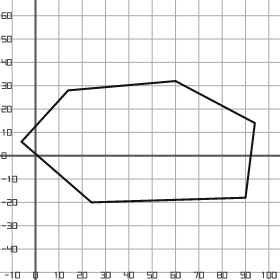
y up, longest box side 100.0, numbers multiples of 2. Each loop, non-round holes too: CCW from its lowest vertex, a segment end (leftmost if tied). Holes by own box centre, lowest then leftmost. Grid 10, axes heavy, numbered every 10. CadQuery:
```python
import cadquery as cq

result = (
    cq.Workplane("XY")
    .moveTo(24.0, -20.0)
    .lineTo(90.0, -18.0)
    .lineTo(94.0, 14.0)
    .lineTo(60.0, 32.0)
    .lineTo(14.0, 28.0)
    .lineTo(-6.0, 6.0)
    .close()
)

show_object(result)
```